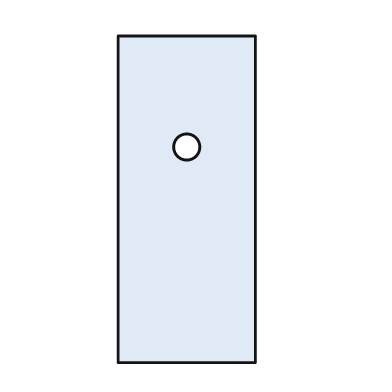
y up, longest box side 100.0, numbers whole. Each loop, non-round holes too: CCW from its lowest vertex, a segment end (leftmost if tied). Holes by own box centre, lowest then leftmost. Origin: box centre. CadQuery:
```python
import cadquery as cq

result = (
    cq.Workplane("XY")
    .moveTo(-21.0, -50.0)
    .lineTo(21.0, -50.0)
    .lineTo(21.0, 50.0)
    .lineTo(-21.0, 50.0)
    .close()
    .moveTo(0.0, 16.0)
    .circle(4.0)
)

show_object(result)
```